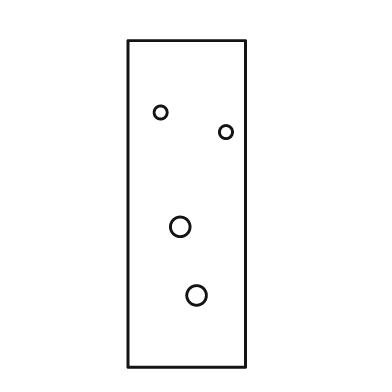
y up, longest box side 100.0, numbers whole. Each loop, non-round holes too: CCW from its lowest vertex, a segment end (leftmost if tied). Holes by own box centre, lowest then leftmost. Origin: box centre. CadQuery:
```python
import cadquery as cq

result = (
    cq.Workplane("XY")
    .moveTo(-18.0, -50.0)
    .lineTo(18.0, -50.0)
    .lineTo(18.0, 50.0)
    .lineTo(-18.0, 50.0)
    .close()
    .moveTo(3.0, -28.0)
    .circle(3.0)
    .moveTo(-2.0, -7.0)
    .circle(3.0)
    .moveTo(12.0, 22.0)
    .circle(2.0)
    .moveTo(-8.0, 28.0)
    .circle(2.0)
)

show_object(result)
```